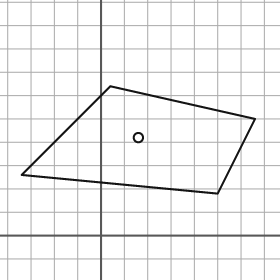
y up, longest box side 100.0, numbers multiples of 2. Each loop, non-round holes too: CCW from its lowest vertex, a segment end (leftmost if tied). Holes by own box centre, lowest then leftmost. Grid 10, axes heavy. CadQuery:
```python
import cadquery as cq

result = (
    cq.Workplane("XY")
    .moveTo(50.0, 18.0)
    .lineTo(66.0, 50.0)
    .lineTo(4.0, 64.0)
    .lineTo(-34.0, 26.0)
    .close()
    .moveTo(16.0, 42.0)
    .circle(2.0)
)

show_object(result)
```